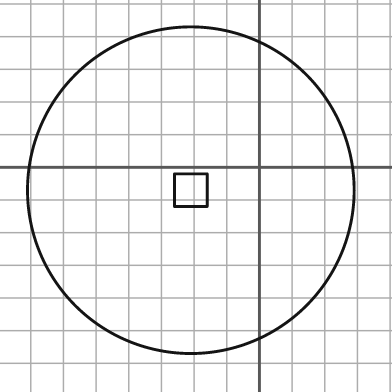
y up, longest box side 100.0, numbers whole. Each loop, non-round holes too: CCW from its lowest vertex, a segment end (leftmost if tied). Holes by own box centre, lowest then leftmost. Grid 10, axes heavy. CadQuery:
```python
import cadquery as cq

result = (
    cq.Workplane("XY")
    .moveTo(-21.0, -7.0)
    .circle(50.0)
    .moveTo(-26.0, -12.0)
    .lineTo(-16.0, -12.0)
    .lineTo(-16.0, -2.0)
    .lineTo(-26.0, -2.0)
    .close()
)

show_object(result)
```